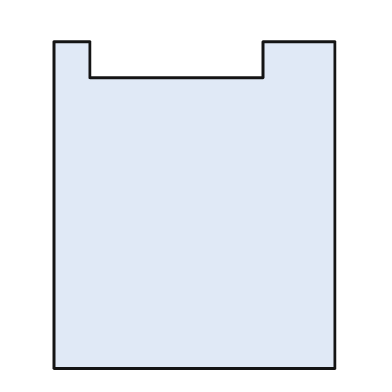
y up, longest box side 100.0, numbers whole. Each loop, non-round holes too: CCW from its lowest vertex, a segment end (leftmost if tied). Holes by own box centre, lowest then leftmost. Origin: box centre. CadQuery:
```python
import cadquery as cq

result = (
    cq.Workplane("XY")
    .moveTo(-43.0, -50.0)
    .lineTo(43.0, -50.0)
    .lineTo(43.0, 50.0)
    .lineTo(21.0, 50.0)
    .lineTo(21.0, 39.0)
    .lineTo(-32.0, 39.0)
    .lineTo(-32.0, 50.0)
    .lineTo(-43.0, 50.0)
    .close()
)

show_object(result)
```